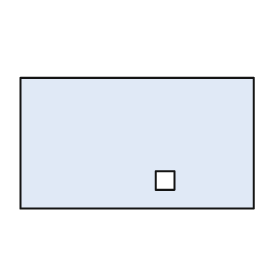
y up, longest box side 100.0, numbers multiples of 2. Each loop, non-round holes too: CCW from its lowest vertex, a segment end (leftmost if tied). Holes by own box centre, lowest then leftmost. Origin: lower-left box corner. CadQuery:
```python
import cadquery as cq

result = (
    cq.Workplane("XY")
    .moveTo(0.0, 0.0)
    .lineTo(100.0, 0.0)
    .lineTo(100.0, 56.0)
    .lineTo(0.0, 56.0)
    .close()
    .moveTo(58.0, 8.0)
    .lineTo(66.0, 8.0)
    .lineTo(66.0, 16.0)
    .lineTo(58.0, 16.0)
    .close()
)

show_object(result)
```